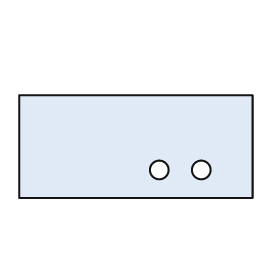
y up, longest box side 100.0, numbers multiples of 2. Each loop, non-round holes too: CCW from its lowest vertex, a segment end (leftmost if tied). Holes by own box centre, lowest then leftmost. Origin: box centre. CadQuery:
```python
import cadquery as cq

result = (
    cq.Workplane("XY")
    .moveTo(-50.0, -22.0)
    .lineTo(50.0, -22.0)
    .lineTo(50.0, 22.0)
    .lineTo(-50.0, 22.0)
    .close()
    .moveTo(10.0, -10.0)
    .circle(4.0)
    .moveTo(28.0, -10.0)
    .circle(4.0)
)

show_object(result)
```